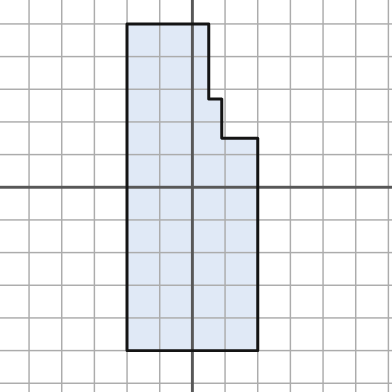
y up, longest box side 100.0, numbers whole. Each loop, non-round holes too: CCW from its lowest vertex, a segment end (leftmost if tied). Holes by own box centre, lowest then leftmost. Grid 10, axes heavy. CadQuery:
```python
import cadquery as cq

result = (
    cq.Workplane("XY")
    .moveTo(-20.0, -50.0)
    .lineTo(20.0, -50.0)
    .lineTo(20.0, 15.0)
    .lineTo(9.0, 15.0)
    .lineTo(9.0, 27.0)
    .lineTo(5.0, 27.0)
    .lineTo(5.0, 50.0)
    .lineTo(-20.0, 50.0)
    .close()
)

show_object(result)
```